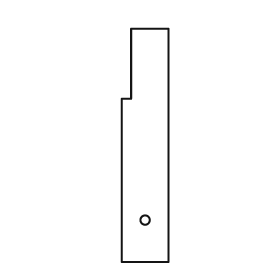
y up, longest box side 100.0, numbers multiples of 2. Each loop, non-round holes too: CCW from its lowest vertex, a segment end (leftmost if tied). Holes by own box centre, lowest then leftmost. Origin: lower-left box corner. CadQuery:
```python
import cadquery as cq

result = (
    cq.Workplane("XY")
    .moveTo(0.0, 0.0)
    .lineTo(20.0, 0.0)
    .lineTo(20.0, 100.0)
    .lineTo(4.0, 100.0)
    .lineTo(4.0, 70.0)
    .lineTo(0.0, 70.0)
    .close()
    .moveTo(10.0, 18.0)
    .circle(2.0)
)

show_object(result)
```